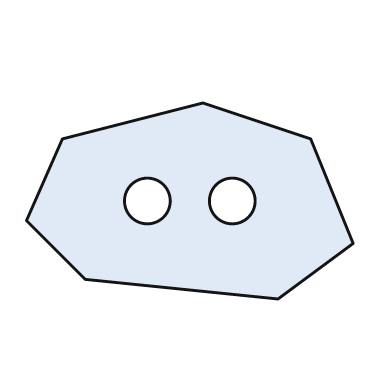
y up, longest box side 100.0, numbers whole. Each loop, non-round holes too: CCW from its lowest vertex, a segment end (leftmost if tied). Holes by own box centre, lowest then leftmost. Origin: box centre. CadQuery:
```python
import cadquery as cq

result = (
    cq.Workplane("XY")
    .moveTo(27.0, -30.0)
    .lineTo(50.0, -13.0)
    .lineTo(37.0, 19.0)
    .lineTo(4.0, 30.0)
    .lineTo(-39.0, 19.0)
    .lineTo(-50.0, -6.0)
    .lineTo(-32.0, -24.0)
    .close()
    .moveTo(-13.0, 0.0)
    .circle(7.0)
    .moveTo(13.0, 0.0)
    .circle(7.0)
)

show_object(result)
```